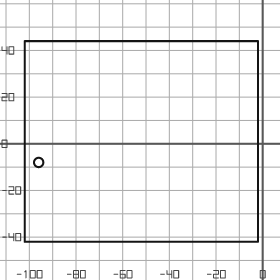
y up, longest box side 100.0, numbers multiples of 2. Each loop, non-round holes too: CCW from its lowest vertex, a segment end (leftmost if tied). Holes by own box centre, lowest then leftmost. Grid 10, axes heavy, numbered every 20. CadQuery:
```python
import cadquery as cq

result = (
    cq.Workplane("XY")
    .moveTo(-102.0, -42.0)
    .lineTo(-2.0, -42.0)
    .lineTo(-2.0, 44.0)
    .lineTo(-102.0, 44.0)
    .close()
    .moveTo(-96.0, -8.0)
    .circle(2.0)
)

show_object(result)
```